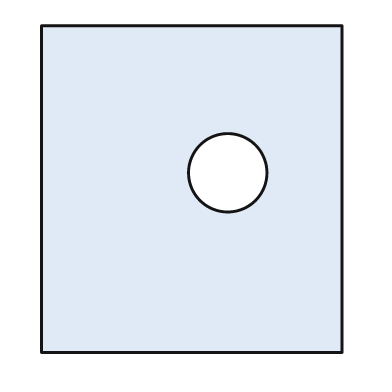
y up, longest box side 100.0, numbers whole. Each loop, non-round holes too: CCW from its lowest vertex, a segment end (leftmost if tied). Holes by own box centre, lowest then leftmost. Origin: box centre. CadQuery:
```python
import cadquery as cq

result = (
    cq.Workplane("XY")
    .moveTo(-46.0, -50.0)
    .lineTo(46.0, -50.0)
    .lineTo(46.0, 50.0)
    .lineTo(-46.0, 50.0)
    .close()
    .moveTo(11.0, 5.0)
    .circle(12.0)
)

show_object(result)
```